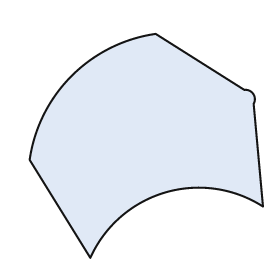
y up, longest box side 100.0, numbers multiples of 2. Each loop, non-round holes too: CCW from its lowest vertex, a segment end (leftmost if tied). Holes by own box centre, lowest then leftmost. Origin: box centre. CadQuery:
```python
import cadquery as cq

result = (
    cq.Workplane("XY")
    .moveTo(-24.0, -48.0)
    .threePointArc((8.0, -20.0), (50.0, -26.0))
    .lineTo(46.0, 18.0)
    .threePointArc((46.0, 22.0), (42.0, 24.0))
    .lineTo(4.0, 48.0)
    .threePointArc((-32.0, 30.0), (-50.0, -6.0))
    .close()
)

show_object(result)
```